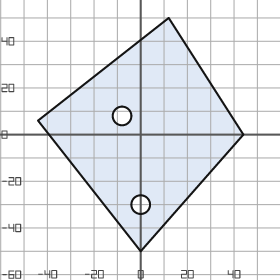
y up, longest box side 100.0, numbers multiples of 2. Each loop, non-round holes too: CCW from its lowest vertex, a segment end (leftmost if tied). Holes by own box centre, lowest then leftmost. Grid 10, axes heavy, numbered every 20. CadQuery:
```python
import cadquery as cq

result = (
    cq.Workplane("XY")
    .moveTo(0.0, -50.0)
    .lineTo(44.0, 0.0)
    .lineTo(12.0, 50.0)
    .lineTo(-44.0, 6.0)
    .close()
    .moveTo(0.0, -30.0)
    .circle(4.0)
    .moveTo(-8.0, 8.0)
    .circle(4.0)
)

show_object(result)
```